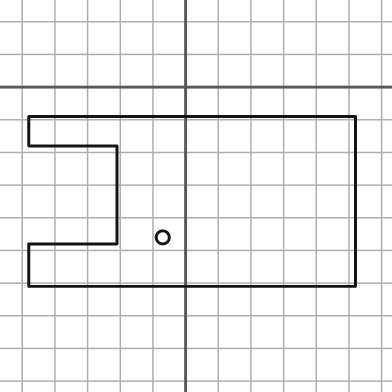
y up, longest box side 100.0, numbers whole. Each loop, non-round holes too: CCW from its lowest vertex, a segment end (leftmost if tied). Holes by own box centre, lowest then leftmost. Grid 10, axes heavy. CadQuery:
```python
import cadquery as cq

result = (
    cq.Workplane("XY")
    .moveTo(-48.0, -61.0)
    .lineTo(52.0, -61.0)
    .lineTo(52.0, -9.0)
    .lineTo(-48.0, -9.0)
    .lineTo(-48.0, -18.0)
    .lineTo(-21.0, -18.0)
    .lineTo(-21.0, -48.0)
    .lineTo(-48.0, -48.0)
    .close()
    .moveTo(-7.0, -46.0)
    .circle(2.0)
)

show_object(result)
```